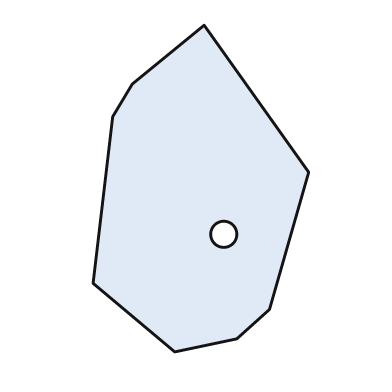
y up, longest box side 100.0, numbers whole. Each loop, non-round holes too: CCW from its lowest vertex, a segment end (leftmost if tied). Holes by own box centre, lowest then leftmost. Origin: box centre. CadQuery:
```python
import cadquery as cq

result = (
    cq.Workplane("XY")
    .moveTo(-8.0, -50.0)
    .lineTo(11.0, -46.0)
    .lineTo(21.0, -37.0)
    .lineTo(33.0, 5.0)
    .lineTo(1.0, 50.0)
    .lineTo(-21.0, 32.0)
    .lineTo(-27.0, 22.0)
    .lineTo(-33.0, -29.0)
    .close()
    .moveTo(7.0, -14.0)
    .circle(4.0)
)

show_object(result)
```